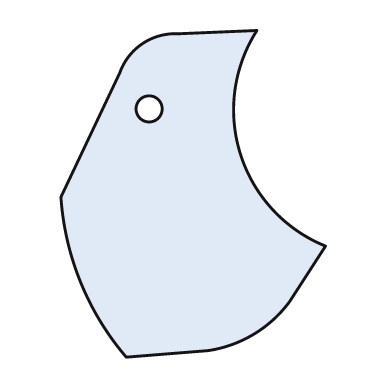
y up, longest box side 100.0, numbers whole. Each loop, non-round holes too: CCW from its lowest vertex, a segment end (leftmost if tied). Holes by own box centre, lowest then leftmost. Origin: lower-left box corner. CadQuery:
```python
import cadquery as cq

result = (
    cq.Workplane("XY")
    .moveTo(20.0, 0.0)
    .lineTo(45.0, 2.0)
    .threePointArc((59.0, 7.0), (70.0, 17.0))
    .lineTo(81.0, 34.0)
    .threePointArc((55.0, 62.0), (60.0, 100.0))
    .lineTo(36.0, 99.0)
    .threePointArc((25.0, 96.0), (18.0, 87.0))
    .lineTo(0.0, 49.0)
    .threePointArc((6.0, 23.0), (20.0, 0.0))
    .close()
    .moveTo(27.0, 76.0)
    .circle(4.0)
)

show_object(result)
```